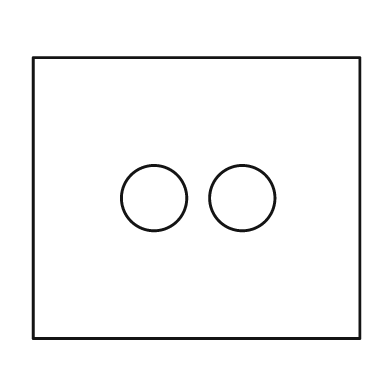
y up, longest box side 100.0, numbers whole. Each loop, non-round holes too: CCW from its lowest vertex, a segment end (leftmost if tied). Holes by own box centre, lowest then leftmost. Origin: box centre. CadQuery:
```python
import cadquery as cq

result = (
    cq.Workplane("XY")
    .moveTo(-50.0, -43.0)
    .lineTo(50.0, -43.0)
    .lineTo(50.0, 43.0)
    .lineTo(-50.0, 43.0)
    .close()
    .moveTo(-13.0, 0.0)
    .circle(10.0)
    .moveTo(14.0, 0.0)
    .circle(10.0)
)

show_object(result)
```